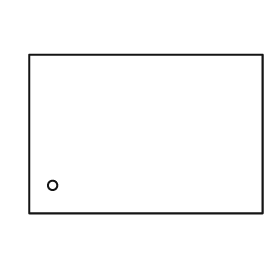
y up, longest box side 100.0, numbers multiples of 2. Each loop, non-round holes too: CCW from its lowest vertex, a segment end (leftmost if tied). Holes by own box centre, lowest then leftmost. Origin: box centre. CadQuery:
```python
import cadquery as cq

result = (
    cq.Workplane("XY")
    .moveTo(-50.0, -34.0)
    .lineTo(50.0, -34.0)
    .lineTo(50.0, 34.0)
    .lineTo(-50.0, 34.0)
    .close()
    .moveTo(-40.0, -22.0)
    .circle(2.0)
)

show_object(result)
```